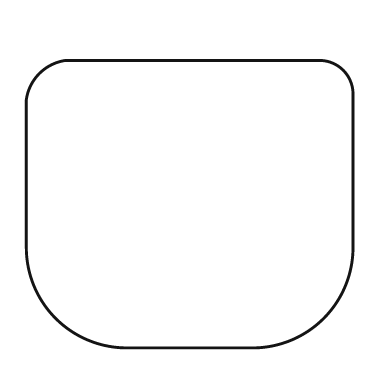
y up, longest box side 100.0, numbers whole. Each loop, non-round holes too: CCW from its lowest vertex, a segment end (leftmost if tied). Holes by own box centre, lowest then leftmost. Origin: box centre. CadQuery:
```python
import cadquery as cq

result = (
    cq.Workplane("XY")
    .moveTo(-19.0, -44.0)
    .lineTo(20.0, -44.0)
    .threePointArc((41.0, -35.0), (50.0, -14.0))
    .lineTo(50.0, 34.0)
    .threePointArc((47.0, 41.0), (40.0, 44.0))
    .lineTo(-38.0, 44.0)
    .threePointArc((-46.0, 40.0), (-50.0, 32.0))
    .lineTo(-50.0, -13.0)
    .threePointArc((-41.0, -35.0), (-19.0, -44.0))
    .close()
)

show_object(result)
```